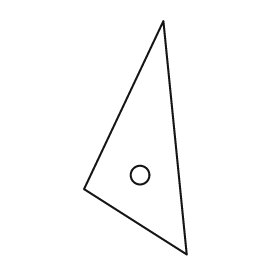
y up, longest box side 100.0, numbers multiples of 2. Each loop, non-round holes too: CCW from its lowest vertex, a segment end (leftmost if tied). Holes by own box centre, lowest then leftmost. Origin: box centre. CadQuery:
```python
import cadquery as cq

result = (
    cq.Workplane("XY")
    .moveTo(22.0, -50.0)
    .lineTo(12.0, 50.0)
    .lineTo(-22.0, -22.0)
    .close()
    .moveTo(2.0, -16.0)
    .circle(4.0)
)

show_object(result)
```